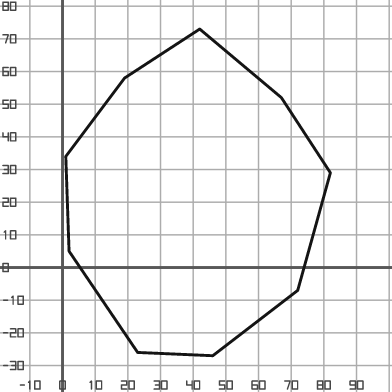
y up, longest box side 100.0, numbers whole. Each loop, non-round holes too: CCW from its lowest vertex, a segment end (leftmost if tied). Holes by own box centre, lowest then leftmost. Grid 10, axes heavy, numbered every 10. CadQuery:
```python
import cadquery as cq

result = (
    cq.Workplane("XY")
    .moveTo(46.0, -27.0)
    .lineTo(72.0, -7.0)
    .lineTo(82.0, 29.0)
    .lineTo(67.0, 52.0)
    .lineTo(42.0, 73.0)
    .lineTo(19.0, 58.0)
    .lineTo(1.0, 34.0)
    .lineTo(2.0, 5.0)
    .lineTo(23.0, -26.0)
    .close()
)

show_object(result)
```